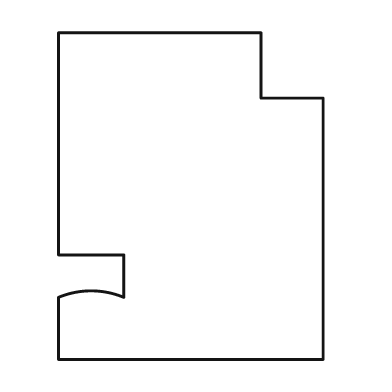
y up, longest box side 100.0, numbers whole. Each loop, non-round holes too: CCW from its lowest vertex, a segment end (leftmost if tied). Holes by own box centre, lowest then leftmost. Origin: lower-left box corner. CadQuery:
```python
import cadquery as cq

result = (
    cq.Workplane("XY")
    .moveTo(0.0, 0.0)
    .lineTo(81.0, 0.0)
    .lineTo(81.0, 80.0)
    .lineTo(62.0, 80.0)
    .lineTo(62.0, 100.0)
    .lineTo(0.0, 100.0)
    .lineTo(0.0, 32.0)
    .lineTo(20.0, 32.0)
    .lineTo(20.0, 19.0)
    .threePointArc((10.0, 21.0), (0.0, 19.0))
    .close()
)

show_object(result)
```